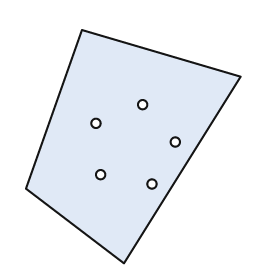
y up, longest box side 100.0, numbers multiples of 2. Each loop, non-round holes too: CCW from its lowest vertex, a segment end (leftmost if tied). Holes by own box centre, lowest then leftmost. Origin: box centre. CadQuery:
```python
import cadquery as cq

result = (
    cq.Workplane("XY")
    .moveTo(-4.0, -50.0)
    .lineTo(46.0, 30.0)
    .lineTo(-22.0, 50.0)
    .lineTo(-46.0, -18.0)
    .close()
    .moveTo(8.0, -16.0)
    .circle(2.0)
    .moveTo(-14.0, -12.0)
    .circle(2.0)
    .moveTo(18.0, 2.0)
    .circle(2.0)
    .moveTo(-16.0, 10.0)
    .circle(2.0)
    .moveTo(4.0, 18.0)
    .circle(2.0)
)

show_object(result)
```